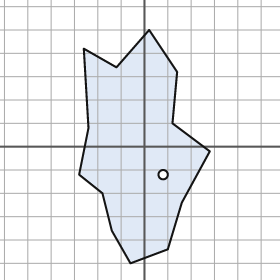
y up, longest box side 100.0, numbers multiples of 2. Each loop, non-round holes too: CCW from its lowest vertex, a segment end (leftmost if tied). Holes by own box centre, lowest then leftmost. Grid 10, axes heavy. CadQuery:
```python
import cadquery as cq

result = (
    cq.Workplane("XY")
    .moveTo(-6.0, -50.0)
    .lineTo(10.0, -44.0)
    .lineTo(16.0, -24.0)
    .lineTo(28.0, -2.0)
    .lineTo(12.0, 10.0)
    .lineTo(14.0, 32.0)
    .lineTo(2.0, 50.0)
    .lineTo(-12.0, 34.0)
    .lineTo(-26.0, 42.0)
    .lineTo(-24.0, 8.0)
    .lineTo(-28.0, -12.0)
    .lineTo(-18.0, -20.0)
    .lineTo(-14.0, -36.0)
    .close()
    .moveTo(8.0, -12.0)
    .circle(2.0)
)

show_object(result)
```